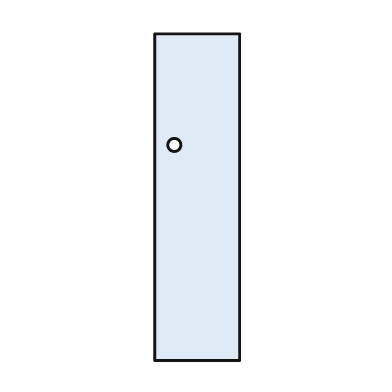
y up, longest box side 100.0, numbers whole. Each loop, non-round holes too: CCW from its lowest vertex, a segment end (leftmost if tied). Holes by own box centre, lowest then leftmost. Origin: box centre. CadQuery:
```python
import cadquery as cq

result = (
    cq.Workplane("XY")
    .moveTo(-13.0, -50.0)
    .lineTo(13.0, -50.0)
    .lineTo(13.0, 50.0)
    .lineTo(-13.0, 50.0)
    .close()
    .moveTo(-7.0, 16.0)
    .circle(2.0)
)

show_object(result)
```